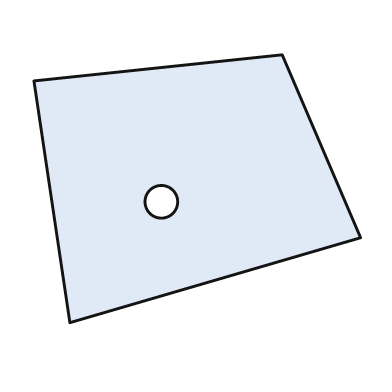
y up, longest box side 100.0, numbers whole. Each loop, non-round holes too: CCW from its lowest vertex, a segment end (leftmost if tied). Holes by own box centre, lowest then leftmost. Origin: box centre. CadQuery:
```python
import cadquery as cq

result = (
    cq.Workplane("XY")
    .moveTo(-39.0, -41.0)
    .lineTo(50.0, -15.0)
    .lineTo(26.0, 41.0)
    .lineTo(-50.0, 33.0)
    .close()
    .moveTo(-11.0, -4.0)
    .circle(5.0)
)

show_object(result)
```